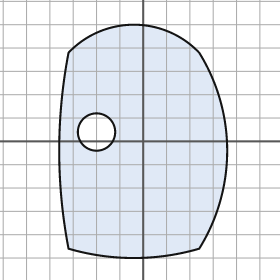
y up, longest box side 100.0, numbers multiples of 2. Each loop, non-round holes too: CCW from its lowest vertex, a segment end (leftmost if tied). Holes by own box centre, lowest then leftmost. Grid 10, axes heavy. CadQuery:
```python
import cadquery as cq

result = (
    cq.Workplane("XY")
    .moveTo(-32.0, -46.0)
    .threePointArc((-4.0, -50.0), (24.0, -46.0))
    .threePointArc((36.0, -4.0), (24.0, 38.0))
    .threePointArc((-4.0, 50.0), (-32.0, 38.0))
    .threePointArc((-36.0, -4.0), (-32.0, -46.0))
    .close()
    .moveTo(-20.0, 4.0)
    .circle(8.0)
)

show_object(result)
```